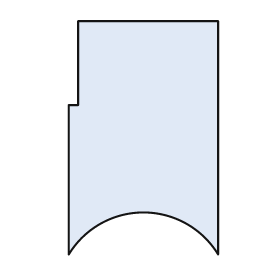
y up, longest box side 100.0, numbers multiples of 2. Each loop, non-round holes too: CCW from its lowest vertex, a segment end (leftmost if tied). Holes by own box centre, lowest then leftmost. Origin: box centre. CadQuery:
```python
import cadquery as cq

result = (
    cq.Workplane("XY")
    .moveTo(-32.0, -50.0)
    .threePointArc((0.0, -32.0), (32.0, -50.0))
    .lineTo(32.0, 50.0)
    .lineTo(-28.0, 50.0)
    .lineTo(-28.0, 14.0)
    .lineTo(-32.0, 14.0)
    .close()
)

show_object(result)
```